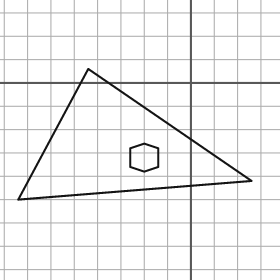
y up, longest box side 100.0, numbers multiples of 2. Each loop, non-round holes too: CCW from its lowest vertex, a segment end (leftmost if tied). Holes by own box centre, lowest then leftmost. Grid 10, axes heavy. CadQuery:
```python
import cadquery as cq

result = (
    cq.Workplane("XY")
    .moveTo(-74.0, -50.0)
    .lineTo(26.0, -42.0)
    .lineTo(-44.0, 6.0)
    .close()
    .moveTo(-20.0, -38.0)
    .lineTo(-14.0, -36.0)
    .lineTo(-14.0, -28.0)
    .lineTo(-20.0, -26.0)
    .lineTo(-26.0, -28.0)
    .lineTo(-26.0, -36.0)
    .close()
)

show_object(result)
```